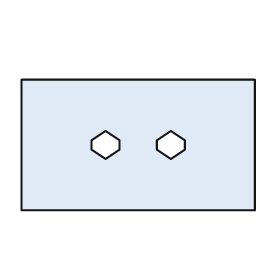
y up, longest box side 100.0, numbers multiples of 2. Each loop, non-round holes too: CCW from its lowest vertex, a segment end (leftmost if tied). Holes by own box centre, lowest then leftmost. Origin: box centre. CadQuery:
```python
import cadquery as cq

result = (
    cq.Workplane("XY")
    .moveTo(-50.0, -28.0)
    .lineTo(50.0, -28.0)
    .lineTo(50.0, 28.0)
    .lineTo(-50.0, 28.0)
    .close()
    .moveTo(-14.0, -6.0)
    .lineTo(-8.0, -2.0)
    .lineTo(-8.0, 2.0)
    .lineTo(-14.0, 6.0)
    .lineTo(-20.0, 2.0)
    .lineTo(-20.0, -2.0)
    .close()
    .moveTo(14.0, -6.0)
    .lineTo(20.0, -2.0)
    .lineTo(20.0, 2.0)
    .lineTo(14.0, 6.0)
    .lineTo(8.0, 2.0)
    .lineTo(8.0, -2.0)
    .close()
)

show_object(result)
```